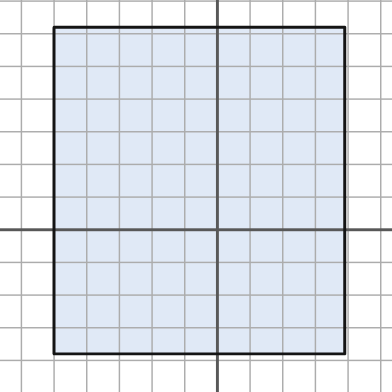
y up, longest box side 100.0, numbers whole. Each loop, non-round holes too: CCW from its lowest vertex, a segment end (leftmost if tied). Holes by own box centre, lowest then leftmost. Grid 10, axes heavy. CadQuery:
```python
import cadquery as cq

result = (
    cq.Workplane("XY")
    .moveTo(-50.0, -38.0)
    .lineTo(39.0, -38.0)
    .lineTo(39.0, 62.0)
    .lineTo(-50.0, 62.0)
    .close()
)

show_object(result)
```